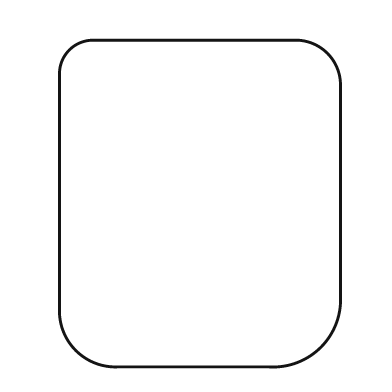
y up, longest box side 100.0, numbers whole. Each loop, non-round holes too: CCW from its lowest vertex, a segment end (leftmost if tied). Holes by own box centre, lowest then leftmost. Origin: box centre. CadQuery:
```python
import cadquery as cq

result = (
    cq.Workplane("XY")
    .moveTo(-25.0, -50.0)
    .lineTo(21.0, -50.0)
    .threePointArc((37.0, -44.0), (43.0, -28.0))
    .lineTo(43.0, 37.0)
    .threePointArc((39.0, 46.0), (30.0, 50.0))
    .lineTo(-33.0, 50.0)
    .threePointArc((-40.0, 47.0), (-43.0, 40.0))
    .lineTo(-43.0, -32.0)
    .threePointArc((-38.0, -45.0), (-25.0, -50.0))
    .close()
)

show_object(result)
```